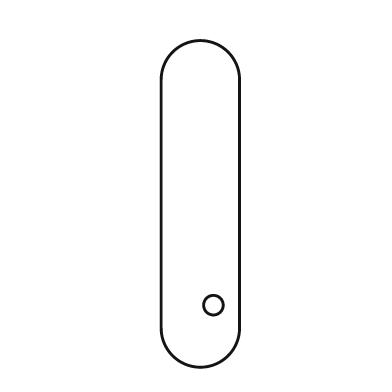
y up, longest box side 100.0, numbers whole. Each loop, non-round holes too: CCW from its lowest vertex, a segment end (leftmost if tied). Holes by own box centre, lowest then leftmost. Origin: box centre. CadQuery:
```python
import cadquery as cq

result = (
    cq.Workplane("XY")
    .moveTo(-12.0, -38.0)
    .threePointArc((0.0, -50.0), (12.0, -38.0))
    .lineTo(12.0, 38.0)
    .threePointArc((0.0, 50.0), (-12.0, 38.0))
    .close()
    .moveTo(4.0, -31.0)
    .circle(3.0)
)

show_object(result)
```